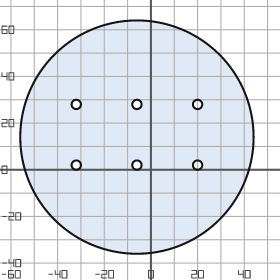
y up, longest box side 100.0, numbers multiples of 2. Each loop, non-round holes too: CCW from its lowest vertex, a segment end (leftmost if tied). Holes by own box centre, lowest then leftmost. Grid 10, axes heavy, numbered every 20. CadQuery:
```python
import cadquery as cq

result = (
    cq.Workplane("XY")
    .moveTo(-6.0, 14.0)
    .circle(50.0)
    .moveTo(-32.0, 2.0)
    .circle(2.0)
    .moveTo(-6.0, 2.0)
    .circle(2.0)
    .moveTo(20.0, 2.0)
    .circle(2.0)
    .moveTo(-32.0, 28.0)
    .circle(2.0)
    .moveTo(-6.0, 28.0)
    .circle(2.0)
    .moveTo(20.0, 28.0)
    .circle(2.0)
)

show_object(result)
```